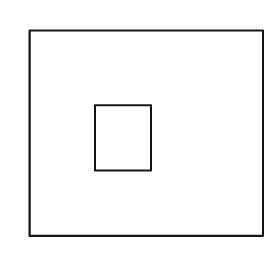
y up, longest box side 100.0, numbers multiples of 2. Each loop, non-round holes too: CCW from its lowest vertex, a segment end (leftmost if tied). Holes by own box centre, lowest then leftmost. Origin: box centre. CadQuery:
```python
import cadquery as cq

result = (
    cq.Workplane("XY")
    .moveTo(-50.0, -44.0)
    .lineTo(50.0, -44.0)
    .lineTo(50.0, 44.0)
    .lineTo(-50.0, 44.0)
    .close()
    .moveTo(-22.0, -16.0)
    .lineTo(2.0, -16.0)
    .lineTo(2.0, 12.0)
    .lineTo(-22.0, 12.0)
    .close()
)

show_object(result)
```